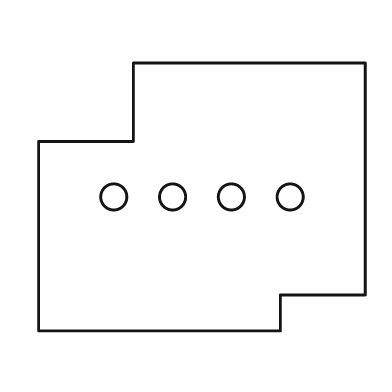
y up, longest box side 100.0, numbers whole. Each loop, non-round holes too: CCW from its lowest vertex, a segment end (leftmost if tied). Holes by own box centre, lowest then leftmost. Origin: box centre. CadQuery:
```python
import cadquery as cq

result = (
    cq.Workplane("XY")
    .moveTo(-50.0, -41.0)
    .lineTo(24.0, -41.0)
    .lineTo(24.0, -30.0)
    .lineTo(50.0, -30.0)
    .lineTo(50.0, 41.0)
    .lineTo(-21.0, 41.0)
    .lineTo(-21.0, 17.0)
    .lineTo(-50.0, 17.0)
    .close()
    .moveTo(-27.0, 0.0)
    .circle(4.0)
    .moveTo(-9.0, 0.0)
    .circle(4.0)
    .moveTo(9.0, 0.0)
    .circle(4.0)
    .moveTo(27.0, 0.0)
    .circle(4.0)
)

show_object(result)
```